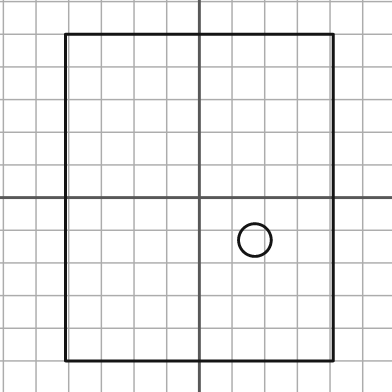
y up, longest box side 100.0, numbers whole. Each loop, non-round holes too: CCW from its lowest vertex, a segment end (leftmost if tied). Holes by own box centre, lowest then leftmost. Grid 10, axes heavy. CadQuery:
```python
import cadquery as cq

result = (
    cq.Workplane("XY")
    .moveTo(-41.0, -50.0)
    .lineTo(41.0, -50.0)
    .lineTo(41.0, 50.0)
    .lineTo(-41.0, 50.0)
    .close()
    .moveTo(17.0, -13.0)
    .circle(5.0)
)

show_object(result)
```